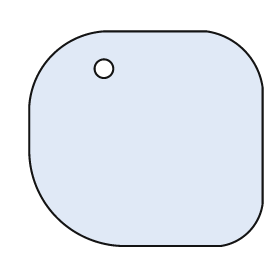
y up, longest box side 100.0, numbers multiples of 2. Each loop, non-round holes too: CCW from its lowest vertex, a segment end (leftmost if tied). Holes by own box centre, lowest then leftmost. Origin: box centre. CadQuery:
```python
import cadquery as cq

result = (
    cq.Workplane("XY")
    .moveTo(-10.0, -46.0)
    .lineTo(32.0, -46.0)
    .threePointArc((44.0, -40.0), (50.0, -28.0))
    .lineTo(50.0, 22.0)
    .threePointArc((42.0, 38.0), (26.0, 46.0))
    .lineTo(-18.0, 46.0)
    .threePointArc((-40.0, 36.0), (-50.0, 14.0))
    .lineTo(-50.0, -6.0)
    .threePointArc((-38.0, -34.0), (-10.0, -46.0))
    .close()
    .moveTo(-18.0, 30.0)
    .circle(4.0)
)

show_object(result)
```